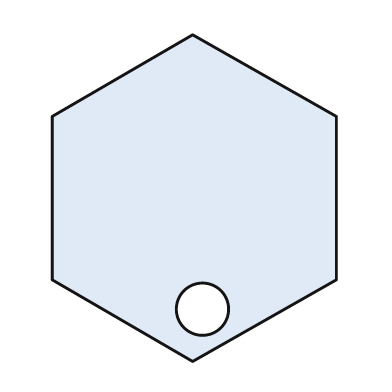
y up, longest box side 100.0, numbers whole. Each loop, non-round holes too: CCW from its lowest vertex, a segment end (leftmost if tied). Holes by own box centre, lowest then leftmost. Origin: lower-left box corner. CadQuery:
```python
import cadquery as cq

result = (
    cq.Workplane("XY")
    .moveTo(43.0, 0.0)
    .lineTo(87.0, 25.0)
    .lineTo(87.0, 75.0)
    .lineTo(43.0, 100.0)
    .lineTo(0.0, 75.0)
    .lineTo(0.0, 25.0)
    .close()
    .moveTo(46.0, 16.0)
    .circle(8.0)
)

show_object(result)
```